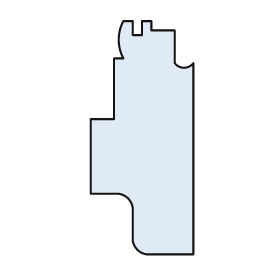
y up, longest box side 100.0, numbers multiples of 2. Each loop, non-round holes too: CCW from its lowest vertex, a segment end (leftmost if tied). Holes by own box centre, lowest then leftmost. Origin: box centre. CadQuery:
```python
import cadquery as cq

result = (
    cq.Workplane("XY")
    .moveTo(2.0, -50.0)
    .lineTo(22.0, -50.0)
    .lineTo(22.0, 32.0)
    .threePointArc((18.0, 30.0), (14.0, 32.0))
    .lineTo(14.0, 46.0)
    .lineTo(4.0, 46.0)
    .lineTo(4.0, 50.0)
    .lineTo(0.0, 50.0)
    .lineTo(0.0, 44.0)
    .lineTo(-4.0, 44.0)
    .lineTo(-4.0, 50.0)
    .lineTo(-8.0, 50.0)
    .threePointArc((-10.0, 42.0), (-8.0, 34.0))
    .lineTo(-12.0, 34.0)
    .lineTo(-12.0, 8.0)
    .lineTo(-22.0, 8.0)
    .lineTo(-22.0, -24.0)
    .lineTo(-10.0, -24.0)
    .threePointArc((-6.0, -26.0), (-4.0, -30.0))
    .lineTo(-4.0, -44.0)
    .threePointArc((-2.0, -48.0), (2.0, -50.0))
    .close()
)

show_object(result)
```